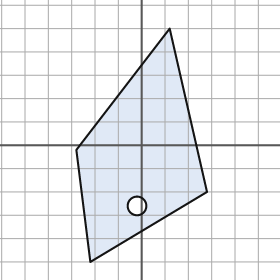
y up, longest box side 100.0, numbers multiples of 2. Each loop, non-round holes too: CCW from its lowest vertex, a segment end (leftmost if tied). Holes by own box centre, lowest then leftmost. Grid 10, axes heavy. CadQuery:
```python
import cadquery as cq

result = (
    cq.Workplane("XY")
    .moveTo(-22.0, -50.0)
    .lineTo(28.0, -20.0)
    .lineTo(12.0, 50.0)
    .lineTo(-28.0, -2.0)
    .close()
    .moveTo(-2.0, -26.0)
    .circle(4.0)
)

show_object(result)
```